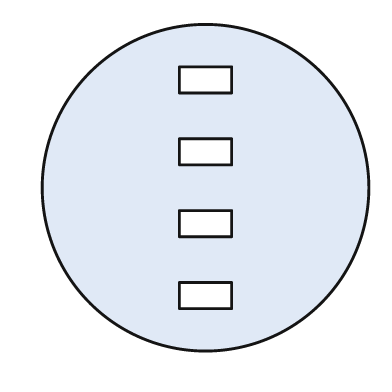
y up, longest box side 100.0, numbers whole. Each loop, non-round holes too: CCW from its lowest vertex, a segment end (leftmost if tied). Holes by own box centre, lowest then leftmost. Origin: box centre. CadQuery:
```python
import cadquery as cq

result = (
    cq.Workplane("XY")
    .moveTo(0.0, 0.0)
    .circle(50.0)
    .moveTo(-8.0, -37.0)
    .lineTo(8.0, -37.0)
    .lineTo(8.0, -29.0)
    .lineTo(-8.0, -29.0)
    .close()
    .moveTo(-8.0, -15.0)
    .lineTo(8.0, -15.0)
    .lineTo(8.0, -7.0)
    .lineTo(-8.0, -7.0)
    .close()
    .moveTo(-8.0, 7.0)
    .lineTo(8.0, 7.0)
    .lineTo(8.0, 15.0)
    .lineTo(-8.0, 15.0)
    .close()
    .moveTo(-8.0, 29.0)
    .lineTo(8.0, 29.0)
    .lineTo(8.0, 37.0)
    .lineTo(-8.0, 37.0)
    .close()
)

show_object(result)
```